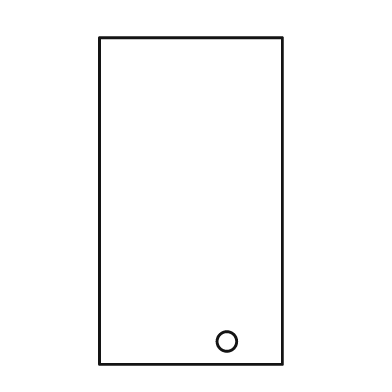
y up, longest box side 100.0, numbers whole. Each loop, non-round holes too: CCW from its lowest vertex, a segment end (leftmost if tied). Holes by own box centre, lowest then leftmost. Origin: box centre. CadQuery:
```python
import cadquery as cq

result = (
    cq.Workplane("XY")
    .moveTo(-28.0, -50.0)
    .lineTo(28.0, -50.0)
    .lineTo(28.0, 50.0)
    .lineTo(-28.0, 50.0)
    .close()
    .moveTo(11.0, -43.0)
    .circle(3.0)
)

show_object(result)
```